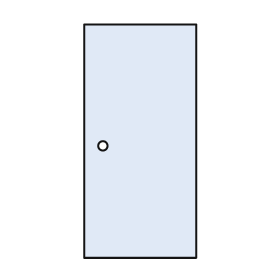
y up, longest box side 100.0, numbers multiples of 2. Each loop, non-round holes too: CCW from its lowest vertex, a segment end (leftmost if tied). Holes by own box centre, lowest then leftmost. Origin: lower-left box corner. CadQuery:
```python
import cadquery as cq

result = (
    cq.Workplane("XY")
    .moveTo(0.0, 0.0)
    .lineTo(48.0, 0.0)
    .lineTo(48.0, 100.0)
    .lineTo(0.0, 100.0)
    .close()
    .moveTo(8.0, 48.0)
    .circle(2.0)
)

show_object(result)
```